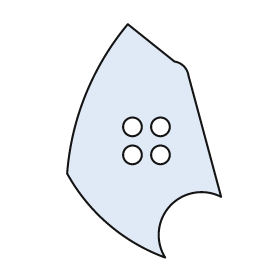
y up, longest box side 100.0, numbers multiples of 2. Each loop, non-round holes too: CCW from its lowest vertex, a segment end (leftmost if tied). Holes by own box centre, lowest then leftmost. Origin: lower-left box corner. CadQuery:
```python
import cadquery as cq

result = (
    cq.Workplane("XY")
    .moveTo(42.0, 0.0)
    .threePointArc((44.0, 22.0), (66.0, 26.0))
    .lineTo(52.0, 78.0)
    .threePointArc((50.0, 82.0), (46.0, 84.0))
    .lineTo(26.0, 100.0)
    .threePointArc((8.0, 70.0), (0.0, 36.0))
    .threePointArc((18.0, 14.0), (42.0, 0.0))
    .close()
    .moveTo(28.0, 44.0)
    .circle(4.0)
    .moveTo(40.0, 44.0)
    .circle(4.0)
    .moveTo(28.0, 56.0)
    .circle(4.0)
    .moveTo(40.0, 56.0)
    .circle(4.0)
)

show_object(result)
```